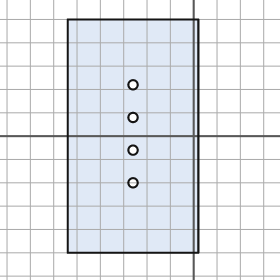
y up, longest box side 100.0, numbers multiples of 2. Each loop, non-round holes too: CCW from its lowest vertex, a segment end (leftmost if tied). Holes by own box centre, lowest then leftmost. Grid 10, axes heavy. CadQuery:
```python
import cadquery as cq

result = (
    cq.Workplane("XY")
    .moveTo(-54.0, -50.0)
    .lineTo(2.0, -50.0)
    .lineTo(2.0, 50.0)
    .lineTo(-54.0, 50.0)
    .close()
    .moveTo(-26.0, -20.0)
    .circle(2.0)
    .moveTo(-26.0, -6.0)
    .circle(2.0)
    .moveTo(-26.0, 8.0)
    .circle(2.0)
    .moveTo(-26.0, 22.0)
    .circle(2.0)
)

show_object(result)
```